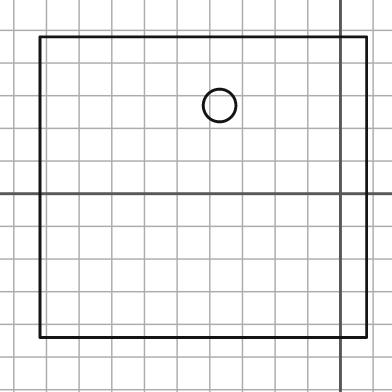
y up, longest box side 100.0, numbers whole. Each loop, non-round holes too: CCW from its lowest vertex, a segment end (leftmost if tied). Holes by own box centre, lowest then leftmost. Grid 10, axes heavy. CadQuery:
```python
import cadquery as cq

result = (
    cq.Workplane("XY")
    .moveTo(-92.0, -44.0)
    .lineTo(8.0, -44.0)
    .lineTo(8.0, 48.0)
    .lineTo(-92.0, 48.0)
    .close()
    .moveTo(-37.0, 27.0)
    .circle(5.0)
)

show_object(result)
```